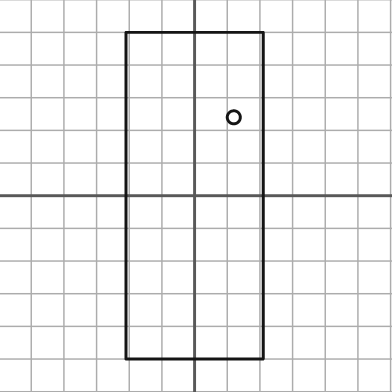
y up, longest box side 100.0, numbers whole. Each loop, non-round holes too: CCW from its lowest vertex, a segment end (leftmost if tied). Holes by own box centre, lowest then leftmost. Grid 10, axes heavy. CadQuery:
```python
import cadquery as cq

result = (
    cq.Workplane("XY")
    .moveTo(-21.0, -50.0)
    .lineTo(21.0, -50.0)
    .lineTo(21.0, 50.0)
    .lineTo(-21.0, 50.0)
    .close()
    .moveTo(12.0, 24.0)
    .circle(2.0)
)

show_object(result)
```